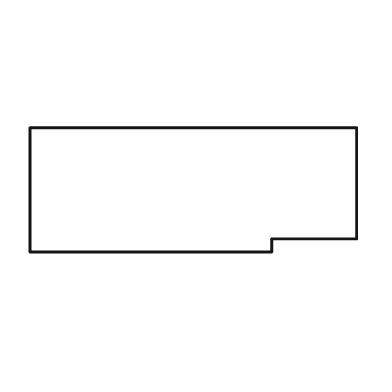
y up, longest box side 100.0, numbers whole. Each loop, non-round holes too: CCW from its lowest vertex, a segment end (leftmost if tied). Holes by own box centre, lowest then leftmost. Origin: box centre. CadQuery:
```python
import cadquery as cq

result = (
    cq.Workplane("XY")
    .moveTo(-50.0, -19.0)
    .lineTo(24.0, -19.0)
    .lineTo(24.0, -15.0)
    .lineTo(50.0, -15.0)
    .lineTo(50.0, 19.0)
    .lineTo(-50.0, 19.0)
    .close()
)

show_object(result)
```